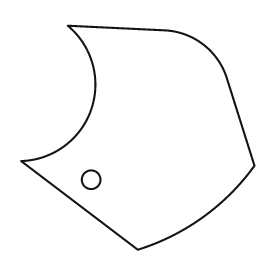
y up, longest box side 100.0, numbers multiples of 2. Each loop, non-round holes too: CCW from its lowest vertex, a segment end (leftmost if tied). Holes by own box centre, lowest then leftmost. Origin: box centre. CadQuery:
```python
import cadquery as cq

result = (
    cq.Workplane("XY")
    .moveTo(0.0, -48.0)
    .threePointArc((28.0, -34.0), (50.0, -12.0))
    .lineTo(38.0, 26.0)
    .threePointArc((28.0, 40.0), (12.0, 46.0))
    .lineTo(-30.0, 48.0)
    .threePointArc((-20.0, 12.0), (-50.0, -10.0))
    .close()
    .moveTo(-20.0, -18.0)
    .circle(4.0)
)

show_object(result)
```